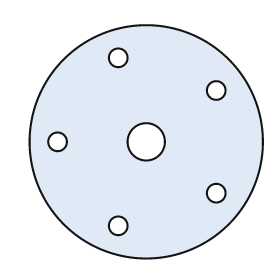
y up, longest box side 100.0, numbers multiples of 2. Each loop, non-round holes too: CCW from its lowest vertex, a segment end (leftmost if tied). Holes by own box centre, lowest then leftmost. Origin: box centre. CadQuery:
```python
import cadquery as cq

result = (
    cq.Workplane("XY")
    .moveTo(0.0, 0.0)
    .circle(50.0)
    .moveTo(-12.0, -36.0)
    .circle(4.0)
    .moveTo(30.0, -22.0)
    .circle(4.0)
    .moveTo(-38.0, 0.0)
    .circle(4.0)
    .moveTo(0.0, 0.0)
    .circle(8.0)
    .moveTo(30.0, 22.0)
    .circle(4.0)
    .moveTo(-12.0, 36.0)
    .circle(4.0)
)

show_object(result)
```